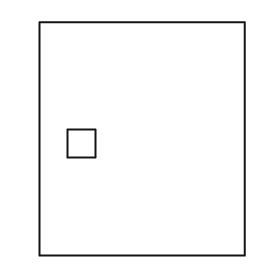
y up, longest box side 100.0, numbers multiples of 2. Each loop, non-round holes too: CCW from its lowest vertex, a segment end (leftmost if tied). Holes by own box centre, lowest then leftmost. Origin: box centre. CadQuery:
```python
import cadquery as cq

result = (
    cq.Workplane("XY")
    .moveTo(-44.0, -50.0)
    .lineTo(44.0, -50.0)
    .lineTo(44.0, 50.0)
    .lineTo(-44.0, 50.0)
    .close()
    .moveTo(-32.0, -8.0)
    .lineTo(-20.0, -8.0)
    .lineTo(-20.0, 4.0)
    .lineTo(-32.0, 4.0)
    .close()
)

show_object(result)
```